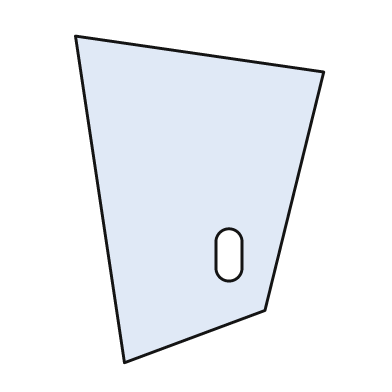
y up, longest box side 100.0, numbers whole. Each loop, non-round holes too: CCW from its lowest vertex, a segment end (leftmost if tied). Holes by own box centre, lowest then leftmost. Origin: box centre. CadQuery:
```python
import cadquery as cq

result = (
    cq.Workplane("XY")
    .moveTo(-23.0, -50.0)
    .lineTo(20.0, -34.0)
    .lineTo(38.0, 39.0)
    .lineTo(-38.0, 50.0)
    .close()
    .moveTo(5.0, -21.0)
    .threePointArc((9.0, -25.0), (13.0, -21.0))
    .lineTo(13.0, -13.0)
    .threePointArc((9.0, -9.0), (5.0, -13.0))
    .close()
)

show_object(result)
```